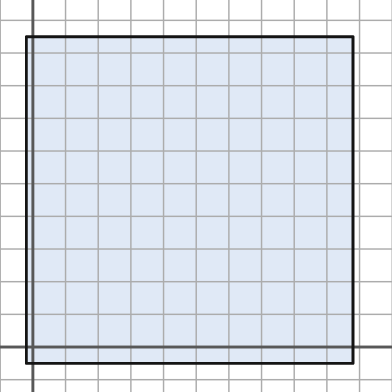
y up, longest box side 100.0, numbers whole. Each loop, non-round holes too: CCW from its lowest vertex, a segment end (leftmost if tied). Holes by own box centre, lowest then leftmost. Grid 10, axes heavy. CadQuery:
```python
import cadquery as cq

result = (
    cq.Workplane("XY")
    .moveTo(-2.0, -5.0)
    .lineTo(98.0, -5.0)
    .lineTo(98.0, 95.0)
    .lineTo(-2.0, 95.0)
    .close()
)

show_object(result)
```